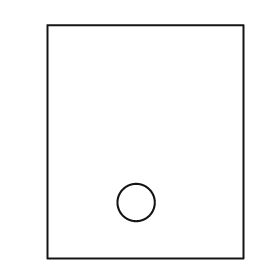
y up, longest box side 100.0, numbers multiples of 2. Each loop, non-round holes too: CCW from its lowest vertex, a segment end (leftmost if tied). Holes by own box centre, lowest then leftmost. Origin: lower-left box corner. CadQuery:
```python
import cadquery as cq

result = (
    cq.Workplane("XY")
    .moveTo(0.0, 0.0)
    .lineTo(84.0, 0.0)
    .lineTo(84.0, 100.0)
    .lineTo(0.0, 100.0)
    .close()
    .moveTo(38.0, 24.0)
    .circle(8.0)
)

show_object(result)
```